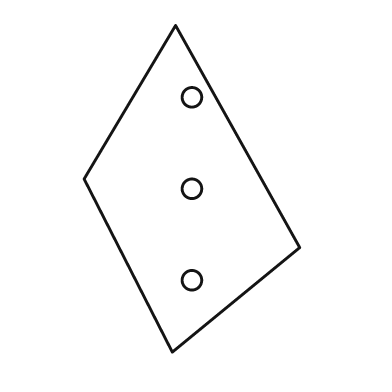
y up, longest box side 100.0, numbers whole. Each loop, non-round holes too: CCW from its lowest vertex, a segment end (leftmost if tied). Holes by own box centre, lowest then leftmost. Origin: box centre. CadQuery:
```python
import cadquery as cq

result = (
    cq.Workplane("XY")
    .moveTo(-6.0, -50.0)
    .lineTo(33.0, -18.0)
    .lineTo(-5.0, 50.0)
    .lineTo(-33.0, 3.0)
    .close()
    .moveTo(0.0, -28.0)
    .circle(3.0)
    .moveTo(0.0, 0.0)
    .circle(3.0)
    .moveTo(0.0, 28.0)
    .circle(3.0)
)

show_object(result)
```